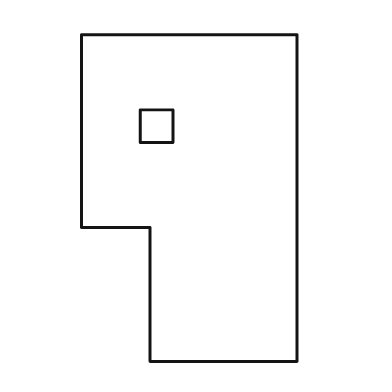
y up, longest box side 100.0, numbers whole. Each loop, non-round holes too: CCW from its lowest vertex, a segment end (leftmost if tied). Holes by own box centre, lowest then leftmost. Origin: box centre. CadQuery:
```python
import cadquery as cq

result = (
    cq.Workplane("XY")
    .moveTo(-12.0, -50.0)
    .lineTo(33.0, -50.0)
    .lineTo(33.0, 50.0)
    .lineTo(-33.0, 50.0)
    .lineTo(-33.0, -9.0)
    .lineTo(-12.0, -9.0)
    .close()
    .moveTo(-15.0, 17.0)
    .lineTo(-5.0, 17.0)
    .lineTo(-5.0, 27.0)
    .lineTo(-15.0, 27.0)
    .close()
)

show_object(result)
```